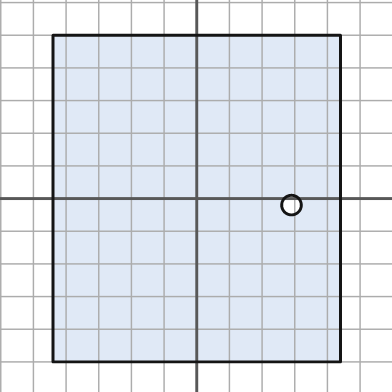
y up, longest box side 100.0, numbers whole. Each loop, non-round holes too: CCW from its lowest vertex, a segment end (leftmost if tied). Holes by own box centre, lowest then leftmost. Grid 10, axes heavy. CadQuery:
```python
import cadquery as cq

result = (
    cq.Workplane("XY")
    .moveTo(-44.0, -50.0)
    .lineTo(44.0, -50.0)
    .lineTo(44.0, 50.0)
    .lineTo(-44.0, 50.0)
    .close()
    .moveTo(29.0, -2.0)
    .circle(3.0)
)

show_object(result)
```